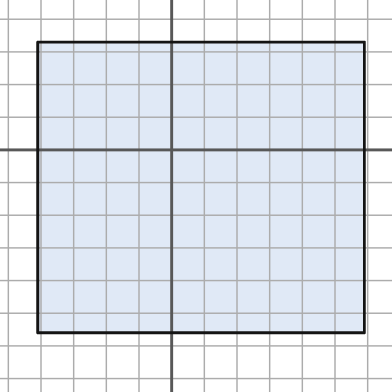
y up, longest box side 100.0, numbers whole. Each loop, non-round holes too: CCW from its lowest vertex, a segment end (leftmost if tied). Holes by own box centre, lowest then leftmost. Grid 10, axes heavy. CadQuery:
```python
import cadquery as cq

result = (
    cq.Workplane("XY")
    .moveTo(-41.0, -56.0)
    .lineTo(59.0, -56.0)
    .lineTo(59.0, 33.0)
    .lineTo(-41.0, 33.0)
    .close()
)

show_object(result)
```